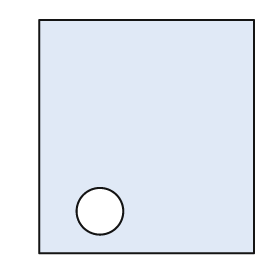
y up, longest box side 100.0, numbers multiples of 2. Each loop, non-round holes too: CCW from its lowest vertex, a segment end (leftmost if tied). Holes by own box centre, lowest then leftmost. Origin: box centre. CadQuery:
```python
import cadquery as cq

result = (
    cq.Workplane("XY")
    .moveTo(-46.0, -50.0)
    .lineTo(46.0, -50.0)
    .lineTo(46.0, 50.0)
    .lineTo(-46.0, 50.0)
    .close()
    .moveTo(-20.0, -32.0)
    .circle(10.0)
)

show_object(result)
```